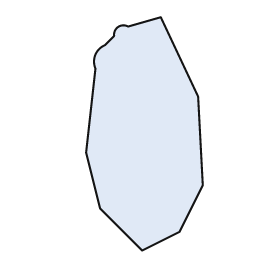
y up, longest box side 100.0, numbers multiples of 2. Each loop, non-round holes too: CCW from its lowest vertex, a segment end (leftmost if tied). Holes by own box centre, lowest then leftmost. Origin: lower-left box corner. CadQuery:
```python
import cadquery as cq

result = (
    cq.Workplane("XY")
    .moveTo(24.0, 0.0)
    .lineTo(40.0, 8.0)
    .lineTo(50.0, 28.0)
    .lineTo(48.0, 66.0)
    .lineTo(32.0, 100.0)
    .lineTo(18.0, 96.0)
    .threePointArc((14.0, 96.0), (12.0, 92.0))
    .lineTo(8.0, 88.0)
    .threePointArc((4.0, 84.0), (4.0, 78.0))
    .lineTo(0.0, 42.0)
    .lineTo(6.0, 18.0)
    .close()
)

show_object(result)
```